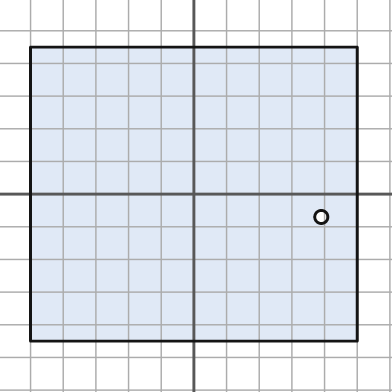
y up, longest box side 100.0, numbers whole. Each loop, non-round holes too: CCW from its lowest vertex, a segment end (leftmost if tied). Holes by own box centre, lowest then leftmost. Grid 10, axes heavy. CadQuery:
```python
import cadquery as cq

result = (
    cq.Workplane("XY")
    .moveTo(-50.0, -45.0)
    .lineTo(50.0, -45.0)
    .lineTo(50.0, 45.0)
    .lineTo(-50.0, 45.0)
    .close()
    .moveTo(39.0, -7.0)
    .circle(2.0)
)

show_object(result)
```